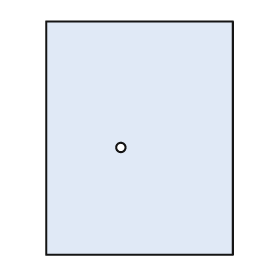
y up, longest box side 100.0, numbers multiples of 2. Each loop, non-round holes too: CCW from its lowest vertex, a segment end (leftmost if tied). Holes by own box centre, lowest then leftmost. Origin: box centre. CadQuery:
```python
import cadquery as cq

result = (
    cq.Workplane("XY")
    .moveTo(-40.0, -50.0)
    .lineTo(40.0, -50.0)
    .lineTo(40.0, 50.0)
    .lineTo(-40.0, 50.0)
    .close()
    .moveTo(-8.0, -4.0)
    .circle(2.0)
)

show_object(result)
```